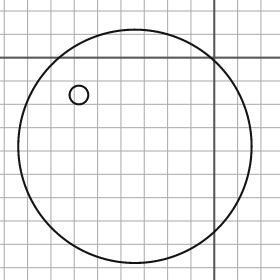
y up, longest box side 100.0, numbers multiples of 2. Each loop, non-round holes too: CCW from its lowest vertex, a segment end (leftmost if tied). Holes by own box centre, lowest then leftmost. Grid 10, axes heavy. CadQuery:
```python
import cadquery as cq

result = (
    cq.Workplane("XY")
    .moveTo(-34.0, -38.0)
    .circle(50.0)
    .moveTo(-58.0, -16.0)
    .circle(4.0)
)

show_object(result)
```